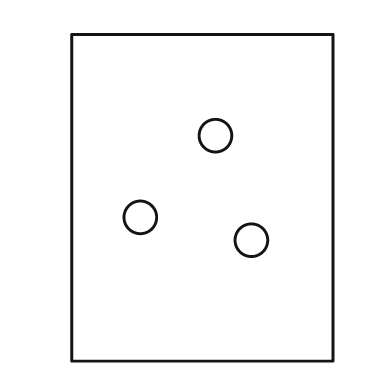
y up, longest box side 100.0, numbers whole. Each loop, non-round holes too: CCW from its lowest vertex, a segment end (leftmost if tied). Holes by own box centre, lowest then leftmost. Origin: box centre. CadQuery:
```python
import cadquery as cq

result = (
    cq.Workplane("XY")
    .moveTo(-40.0, -50.0)
    .lineTo(40.0, -50.0)
    .lineTo(40.0, 50.0)
    .lineTo(-40.0, 50.0)
    .close()
    .moveTo(15.0, -13.0)
    .circle(5.0)
    .moveTo(-19.0, -6.0)
    .circle(5.0)
    .moveTo(4.0, 19.0)
    .circle(5.0)
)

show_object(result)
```